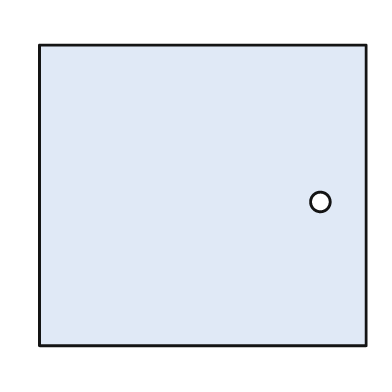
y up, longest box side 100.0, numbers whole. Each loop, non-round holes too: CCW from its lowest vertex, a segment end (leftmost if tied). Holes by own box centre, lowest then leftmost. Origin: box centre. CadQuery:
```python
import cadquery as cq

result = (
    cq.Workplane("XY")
    .moveTo(-50.0, -46.0)
    .lineTo(50.0, -46.0)
    .lineTo(50.0, 46.0)
    .lineTo(-50.0, 46.0)
    .close()
    .moveTo(36.0, -2.0)
    .circle(3.0)
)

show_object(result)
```